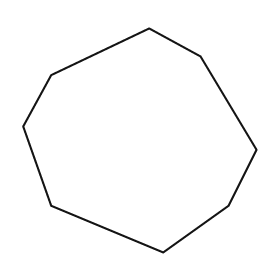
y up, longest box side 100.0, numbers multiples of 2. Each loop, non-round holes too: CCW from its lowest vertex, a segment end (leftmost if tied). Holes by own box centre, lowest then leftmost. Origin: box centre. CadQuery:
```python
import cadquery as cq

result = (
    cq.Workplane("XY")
    .moveTo(10.0, -48.0)
    .lineTo(38.0, -28.0)
    .lineTo(50.0, -4.0)
    .lineTo(26.0, 36.0)
    .lineTo(4.0, 48.0)
    .lineTo(-38.0, 28.0)
    .lineTo(-50.0, 6.0)
    .lineTo(-38.0, -28.0)
    .close()
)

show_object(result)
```